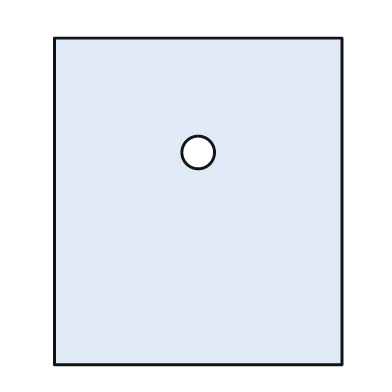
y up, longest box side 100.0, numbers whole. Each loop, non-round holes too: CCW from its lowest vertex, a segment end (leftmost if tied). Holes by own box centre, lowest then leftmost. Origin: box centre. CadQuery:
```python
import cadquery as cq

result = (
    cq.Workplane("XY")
    .moveTo(-44.0, -50.0)
    .lineTo(44.0, -50.0)
    .lineTo(44.0, 50.0)
    .lineTo(-44.0, 50.0)
    .close()
    .moveTo(0.0, 15.0)
    .circle(5.0)
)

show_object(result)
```